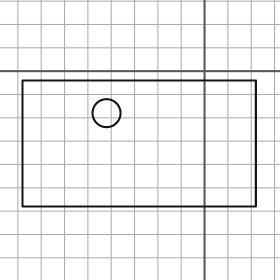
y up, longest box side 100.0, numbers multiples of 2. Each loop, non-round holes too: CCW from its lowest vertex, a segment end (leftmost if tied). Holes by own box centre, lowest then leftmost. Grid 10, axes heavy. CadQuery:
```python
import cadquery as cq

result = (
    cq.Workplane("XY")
    .moveTo(-78.0, -58.0)
    .lineTo(22.0, -58.0)
    .lineTo(22.0, -4.0)
    .lineTo(-78.0, -4.0)
    .close()
    .moveTo(-42.0, -18.0)
    .circle(6.0)
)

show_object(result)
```